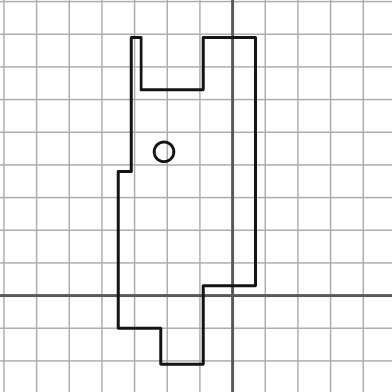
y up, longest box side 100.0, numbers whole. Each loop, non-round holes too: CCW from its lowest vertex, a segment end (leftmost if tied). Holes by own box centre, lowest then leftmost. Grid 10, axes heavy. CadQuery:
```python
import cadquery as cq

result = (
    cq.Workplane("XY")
    .moveTo(-22.0, -21.0)
    .lineTo(-9.0, -21.0)
    .lineTo(-9.0, 3.0)
    .lineTo(7.0, 3.0)
    .lineTo(7.0, 79.0)
    .lineTo(-9.0, 79.0)
    .lineTo(-9.0, 63.0)
    .lineTo(-28.0, 63.0)
    .lineTo(-28.0, 79.0)
    .lineTo(-31.0, 79.0)
    .lineTo(-31.0, 38.0)
    .lineTo(-35.0, 38.0)
    .lineTo(-35.0, -10.0)
    .lineTo(-22.0, -10.0)
    .close()
    .moveTo(-21.0, 44.0)
    .circle(3.0)
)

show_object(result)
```